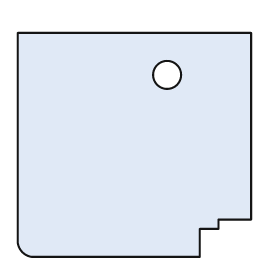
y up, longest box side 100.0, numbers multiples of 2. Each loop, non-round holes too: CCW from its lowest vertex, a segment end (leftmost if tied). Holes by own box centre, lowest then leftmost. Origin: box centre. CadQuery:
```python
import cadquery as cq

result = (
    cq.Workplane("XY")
    .moveTo(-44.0, -48.0)
    .lineTo(28.0, -48.0)
    .lineTo(28.0, -36.0)
    .lineTo(36.0, -36.0)
    .lineTo(36.0, -32.0)
    .lineTo(50.0, -32.0)
    .lineTo(50.0, 48.0)
    .lineTo(-50.0, 48.0)
    .lineTo(-50.0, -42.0)
    .threePointArc((-48.0, -46.0), (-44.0, -48.0))
    .close()
    .moveTo(14.0, 30.0)
    .circle(6.0)
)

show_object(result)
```